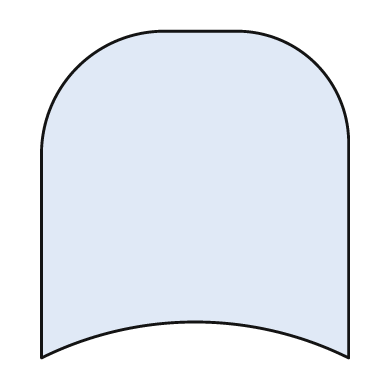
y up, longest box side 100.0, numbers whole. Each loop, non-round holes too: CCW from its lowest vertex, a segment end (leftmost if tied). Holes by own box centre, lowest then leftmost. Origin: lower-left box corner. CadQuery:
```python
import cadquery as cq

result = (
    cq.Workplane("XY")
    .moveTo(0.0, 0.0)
    .threePointArc((47.0, 11.0), (94.0, 0.0))
    .lineTo(94.0, 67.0)
    .threePointArc((84.0, 90.0), (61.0, 100.0))
    .lineTo(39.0, 100.0)
    .threePointArc((11.0, 89.0), (0.0, 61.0))
    .close()
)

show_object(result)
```